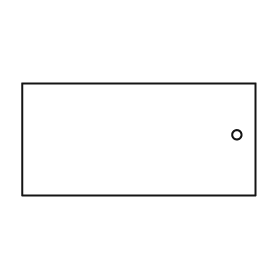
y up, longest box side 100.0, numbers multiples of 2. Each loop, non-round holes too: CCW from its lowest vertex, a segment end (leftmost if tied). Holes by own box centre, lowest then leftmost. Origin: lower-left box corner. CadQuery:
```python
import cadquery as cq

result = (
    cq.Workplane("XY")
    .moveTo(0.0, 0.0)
    .lineTo(100.0, 0.0)
    .lineTo(100.0, 48.0)
    .lineTo(0.0, 48.0)
    .close()
    .moveTo(92.0, 26.0)
    .circle(2.0)
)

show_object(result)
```